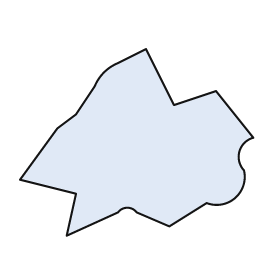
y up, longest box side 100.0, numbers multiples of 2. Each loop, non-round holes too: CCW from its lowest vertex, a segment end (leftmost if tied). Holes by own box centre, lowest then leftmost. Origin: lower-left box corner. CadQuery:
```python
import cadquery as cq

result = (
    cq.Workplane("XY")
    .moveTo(20.0, 0.0)
    .lineTo(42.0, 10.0)
    .threePointArc((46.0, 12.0), (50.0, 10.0))
    .lineTo(64.0, 4.0)
    .lineTo(80.0, 14.0)
    .threePointArc((92.0, 16.0), (96.0, 28.0))
    .threePointArc((94.0, 36.0), (100.0, 42.0))
    .lineTo(84.0, 62.0)
    .lineTo(66.0, 56.0)
    .lineTo(54.0, 80.0)
    .lineTo(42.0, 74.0)
    .threePointArc((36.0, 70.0), (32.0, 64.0))
    .lineTo(24.0, 52.0)
    .lineTo(16.0, 46.0)
    .lineTo(0.0, 24.0)
    .lineTo(24.0, 18.0)
    .close()
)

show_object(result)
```